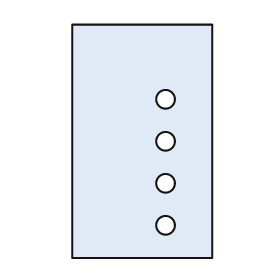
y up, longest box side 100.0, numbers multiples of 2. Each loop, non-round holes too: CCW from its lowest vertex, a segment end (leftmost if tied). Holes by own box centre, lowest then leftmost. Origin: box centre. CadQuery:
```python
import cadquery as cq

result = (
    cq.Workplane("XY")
    .moveTo(-30.0, -50.0)
    .lineTo(30.0, -50.0)
    .lineTo(30.0, 50.0)
    .lineTo(-30.0, 50.0)
    .close()
    .moveTo(10.0, -36.0)
    .circle(4.0)
    .moveTo(10.0, -18.0)
    .circle(4.0)
    .moveTo(10.0, 0.0)
    .circle(4.0)
    .moveTo(10.0, 18.0)
    .circle(4.0)
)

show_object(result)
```